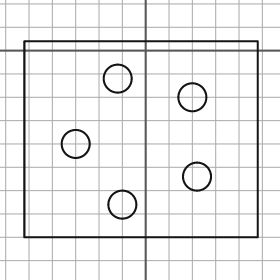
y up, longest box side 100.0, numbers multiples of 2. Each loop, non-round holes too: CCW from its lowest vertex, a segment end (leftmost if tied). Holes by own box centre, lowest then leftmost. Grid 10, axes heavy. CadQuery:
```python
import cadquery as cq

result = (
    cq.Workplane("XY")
    .moveTo(-52.0, -80.0)
    .lineTo(48.0, -80.0)
    .lineTo(48.0, 4.0)
    .lineTo(-52.0, 4.0)
    .close()
    .moveTo(-10.0, -66.0)
    .circle(6.0)
    .moveTo(22.0, -54.0)
    .circle(6.0)
    .moveTo(-30.0, -40.0)
    .circle(6.0)
    .moveTo(20.0, -20.0)
    .circle(6.0)
    .moveTo(-12.0, -12.0)
    .circle(6.0)
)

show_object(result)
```